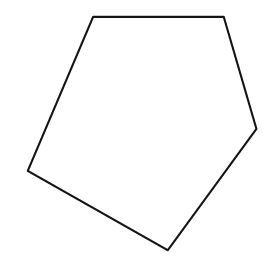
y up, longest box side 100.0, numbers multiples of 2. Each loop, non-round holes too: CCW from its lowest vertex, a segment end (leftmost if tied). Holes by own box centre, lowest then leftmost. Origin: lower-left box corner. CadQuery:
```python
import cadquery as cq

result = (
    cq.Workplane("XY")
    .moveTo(60.0, 0.0)
    .lineTo(98.0, 52.0)
    .lineTo(84.0, 100.0)
    .lineTo(28.0, 100.0)
    .lineTo(0.0, 34.0)
    .close()
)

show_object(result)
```